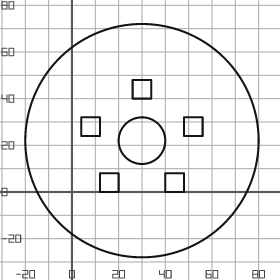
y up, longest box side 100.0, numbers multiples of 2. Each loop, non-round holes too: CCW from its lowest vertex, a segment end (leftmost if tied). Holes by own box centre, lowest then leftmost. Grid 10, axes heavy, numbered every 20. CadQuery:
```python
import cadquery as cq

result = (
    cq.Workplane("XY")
    .moveTo(30.0, 22.0)
    .circle(50.0)
    .moveTo(12.0, 0.0)
    .lineTo(20.0, 0.0)
    .lineTo(20.0, 8.0)
    .lineTo(12.0, 8.0)
    .close()
    .moveTo(40.0, 0.0)
    .lineTo(48.0, 0.0)
    .lineTo(48.0, 8.0)
    .lineTo(40.0, 8.0)
    .close()
    .moveTo(30.0, 22.0)
    .circle(10.0)
    .moveTo(4.0, 24.0)
    .lineTo(12.0, 24.0)
    .lineTo(12.0, 32.0)
    .lineTo(4.0, 32.0)
    .close()
    .moveTo(48.0, 24.0)
    .lineTo(56.0, 24.0)
    .lineTo(56.0, 32.0)
    .lineTo(48.0, 32.0)
    .close()
    .moveTo(26.0, 40.0)
    .lineTo(34.0, 40.0)
    .lineTo(34.0, 48.0)
    .lineTo(26.0, 48.0)
    .close()
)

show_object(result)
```